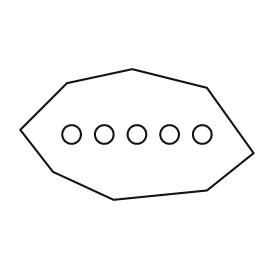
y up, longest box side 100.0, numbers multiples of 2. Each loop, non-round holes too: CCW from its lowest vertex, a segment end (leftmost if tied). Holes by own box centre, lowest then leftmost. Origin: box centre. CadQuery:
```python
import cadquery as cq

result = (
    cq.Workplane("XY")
    .moveTo(-10.0, -28.0)
    .lineTo(30.0, -24.0)
    .lineTo(50.0, -8.0)
    .lineTo(30.0, 20.0)
    .lineTo(-2.0, 28.0)
    .lineTo(-30.0, 22.0)
    .lineTo(-50.0, 2.0)
    .lineTo(-36.0, -16.0)
    .close()
    .moveTo(-28.0, 0.0)
    .circle(4.0)
    .moveTo(-14.0, 0.0)
    .circle(4.0)
    .moveTo(0.0, 0.0)
    .circle(4.0)
    .moveTo(14.0, 0.0)
    .circle(4.0)
    .moveTo(28.0, 0.0)
    .circle(4.0)
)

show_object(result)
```